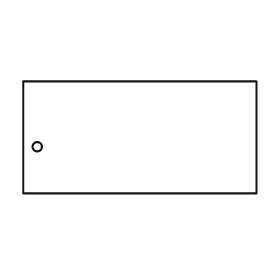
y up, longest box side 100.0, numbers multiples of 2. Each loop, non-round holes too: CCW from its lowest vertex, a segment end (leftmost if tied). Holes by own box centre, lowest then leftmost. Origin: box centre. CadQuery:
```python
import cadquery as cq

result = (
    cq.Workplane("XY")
    .moveTo(-50.0, -24.0)
    .lineTo(50.0, -24.0)
    .lineTo(50.0, 24.0)
    .lineTo(-50.0, 24.0)
    .close()
    .moveTo(-44.0, -4.0)
    .circle(2.0)
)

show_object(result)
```